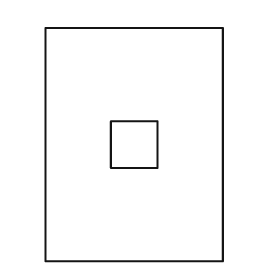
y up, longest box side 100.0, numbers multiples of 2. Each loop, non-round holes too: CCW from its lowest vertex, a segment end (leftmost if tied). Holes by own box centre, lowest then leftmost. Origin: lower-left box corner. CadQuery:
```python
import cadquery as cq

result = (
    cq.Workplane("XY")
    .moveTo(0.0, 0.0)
    .lineTo(76.0, 0.0)
    .lineTo(76.0, 100.0)
    .lineTo(0.0, 100.0)
    .close()
    .moveTo(28.0, 40.0)
    .lineTo(48.0, 40.0)
    .lineTo(48.0, 60.0)
    .lineTo(28.0, 60.0)
    .close()
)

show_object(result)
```